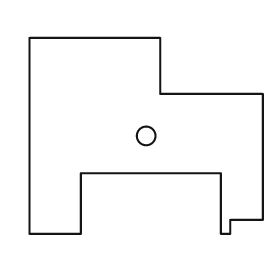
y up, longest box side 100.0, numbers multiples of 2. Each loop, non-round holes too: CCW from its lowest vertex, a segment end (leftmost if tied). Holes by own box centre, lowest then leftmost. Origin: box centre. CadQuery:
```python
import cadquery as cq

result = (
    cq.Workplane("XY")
    .moveTo(-50.0, -42.0)
    .lineTo(-28.0, -42.0)
    .lineTo(-28.0, -16.0)
    .lineTo(32.0, -16.0)
    .lineTo(32.0, -42.0)
    .lineTo(36.0, -42.0)
    .lineTo(36.0, -36.0)
    .lineTo(50.0, -36.0)
    .lineTo(50.0, 18.0)
    .lineTo(6.0, 18.0)
    .lineTo(6.0, 42.0)
    .lineTo(-50.0, 42.0)
    .close()
    .moveTo(0.0, 0.0)
    .circle(4.0)
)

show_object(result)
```